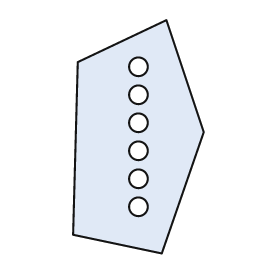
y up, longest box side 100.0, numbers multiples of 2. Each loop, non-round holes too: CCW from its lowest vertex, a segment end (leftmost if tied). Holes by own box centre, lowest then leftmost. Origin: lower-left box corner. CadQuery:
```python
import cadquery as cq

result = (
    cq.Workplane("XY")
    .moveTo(38.0, 0.0)
    .lineTo(56.0, 52.0)
    .lineTo(40.0, 100.0)
    .lineTo(2.0, 82.0)
    .lineTo(0.0, 8.0)
    .close()
    .moveTo(28.0, 20.0)
    .circle(4.0)
    .moveTo(28.0, 32.0)
    .circle(4.0)
    .moveTo(28.0, 44.0)
    .circle(4.0)
    .moveTo(28.0, 56.0)
    .circle(4.0)
    .moveTo(28.0, 68.0)
    .circle(4.0)
    .moveTo(28.0, 80.0)
    .circle(4.0)
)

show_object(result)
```